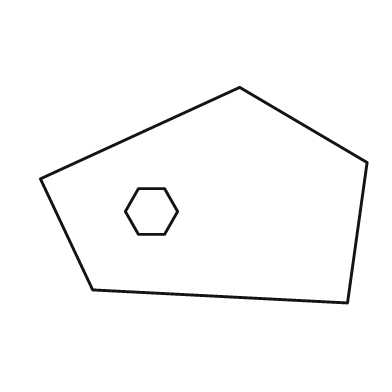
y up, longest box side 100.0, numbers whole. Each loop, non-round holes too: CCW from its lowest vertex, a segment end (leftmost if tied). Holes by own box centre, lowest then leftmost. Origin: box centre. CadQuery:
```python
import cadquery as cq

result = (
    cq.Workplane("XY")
    .moveTo(44.0, -33.0)
    .lineTo(50.0, 10.0)
    .lineTo(11.0, 33.0)
    .lineTo(-50.0, 5.0)
    .lineTo(-34.0, -29.0)
    .close()
    .moveTo(-20.0, -12.0)
    .lineTo(-12.0, -12.0)
    .lineTo(-8.0, -5.0)
    .lineTo(-12.0, 2.0)
    .lineTo(-20.0, 2.0)
    .lineTo(-24.0, -5.0)
    .close()
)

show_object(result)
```